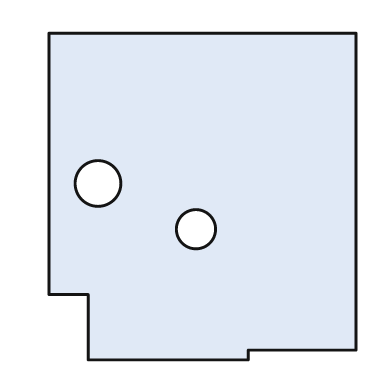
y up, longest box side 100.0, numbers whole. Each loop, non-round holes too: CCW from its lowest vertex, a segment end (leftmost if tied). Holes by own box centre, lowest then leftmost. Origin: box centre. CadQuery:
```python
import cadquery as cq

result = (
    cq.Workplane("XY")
    .moveTo(-35.0, -50.0)
    .lineTo(14.0, -50.0)
    .lineTo(14.0, -47.0)
    .lineTo(47.0, -47.0)
    .lineTo(47.0, 50.0)
    .lineTo(-47.0, 50.0)
    .lineTo(-47.0, -30.0)
    .lineTo(-35.0, -30.0)
    .close()
    .moveTo(-2.0, -10.0)
    .circle(6.0)
    .moveTo(-32.0, 4.0)
    .circle(7.0)
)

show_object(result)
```